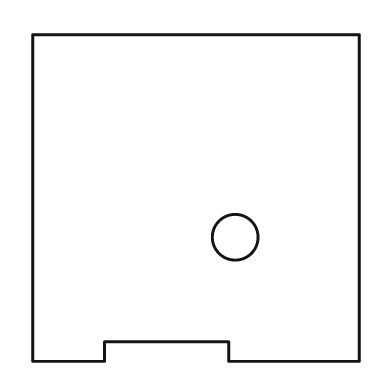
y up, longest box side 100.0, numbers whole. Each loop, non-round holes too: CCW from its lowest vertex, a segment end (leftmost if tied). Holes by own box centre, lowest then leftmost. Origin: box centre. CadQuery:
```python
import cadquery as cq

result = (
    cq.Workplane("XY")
    .moveTo(-50.0, -50.0)
    .lineTo(-28.0, -50.0)
    .lineTo(-28.0, -44.0)
    .lineTo(10.0, -44.0)
    .lineTo(10.0, -50.0)
    .lineTo(50.0, -50.0)
    .lineTo(50.0, 50.0)
    .lineTo(-50.0, 50.0)
    .close()
    .moveTo(12.0, -12.0)
    .circle(7.0)
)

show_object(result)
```